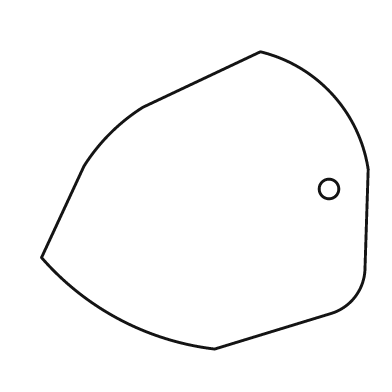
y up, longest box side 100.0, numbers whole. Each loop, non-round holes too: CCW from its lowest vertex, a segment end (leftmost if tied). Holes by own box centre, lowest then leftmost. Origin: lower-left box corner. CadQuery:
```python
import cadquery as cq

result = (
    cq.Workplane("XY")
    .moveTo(53.0, 0.0)
    .lineTo(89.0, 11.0)
    .threePointArc((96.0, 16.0), (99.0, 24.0))
    .lineTo(100.0, 55.0)
    .threePointArc((89.0, 78.0), (67.0, 91.0))
    .lineTo(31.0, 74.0)
    .threePointArc((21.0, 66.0), (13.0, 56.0))
    .lineTo(0.0, 28.0)
    .threePointArc((24.0, 9.0), (53.0, 0.0))
    .close()
    .moveTo(88.0, 49.0)
    .circle(3.0)
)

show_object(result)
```